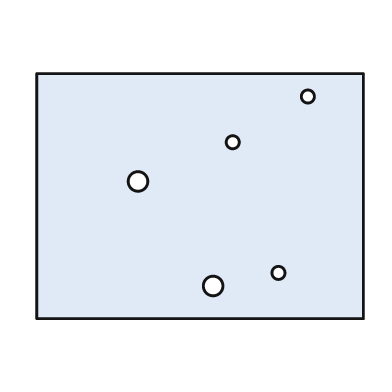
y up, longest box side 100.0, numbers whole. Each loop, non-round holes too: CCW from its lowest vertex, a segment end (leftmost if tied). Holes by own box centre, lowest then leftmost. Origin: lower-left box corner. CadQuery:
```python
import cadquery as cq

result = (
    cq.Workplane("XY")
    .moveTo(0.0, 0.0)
    .lineTo(100.0, 0.0)
    .lineTo(100.0, 75.0)
    .lineTo(0.0, 75.0)
    .close()
    .moveTo(54.0, 10.0)
    .circle(3.0)
    .moveTo(74.0, 14.0)
    .circle(2.0)
    .moveTo(31.0, 42.0)
    .circle(3.0)
    .moveTo(60.0, 54.0)
    .circle(2.0)
    .moveTo(83.0, 68.0)
    .circle(2.0)
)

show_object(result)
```